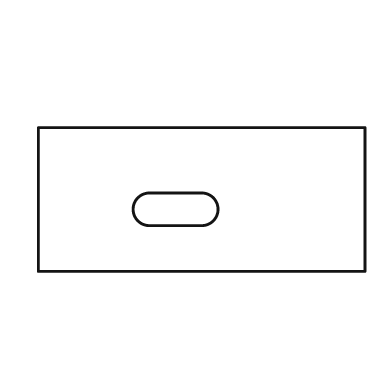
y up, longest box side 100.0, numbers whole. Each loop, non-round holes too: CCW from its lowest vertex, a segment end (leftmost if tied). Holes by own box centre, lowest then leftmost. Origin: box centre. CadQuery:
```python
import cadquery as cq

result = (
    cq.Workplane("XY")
    .moveTo(-50.0, -22.0)
    .lineTo(50.0, -22.0)
    .lineTo(50.0, 22.0)
    .lineTo(-50.0, 22.0)
    .close()
    .moveTo(-16.0, -8.0)
    .lineTo(0.0, -8.0)
    .threePointArc((5.0, -3.0), (0.0, 2.0))
    .lineTo(-16.0, 2.0)
    .threePointArc((-21.0, -3.0), (-16.0, -8.0))
    .close()
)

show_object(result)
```